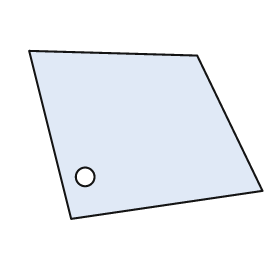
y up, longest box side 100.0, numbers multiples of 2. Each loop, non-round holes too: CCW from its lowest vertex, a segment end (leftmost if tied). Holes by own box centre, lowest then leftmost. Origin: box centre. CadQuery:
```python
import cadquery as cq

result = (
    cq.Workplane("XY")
    .moveTo(-32.0, -36.0)
    .lineTo(50.0, -24.0)
    .lineTo(22.0, 34.0)
    .lineTo(-50.0, 36.0)
    .close()
    .moveTo(-26.0, -18.0)
    .circle(4.0)
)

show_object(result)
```